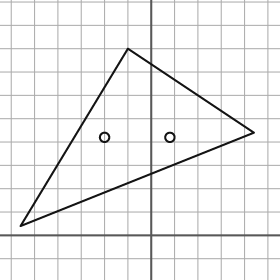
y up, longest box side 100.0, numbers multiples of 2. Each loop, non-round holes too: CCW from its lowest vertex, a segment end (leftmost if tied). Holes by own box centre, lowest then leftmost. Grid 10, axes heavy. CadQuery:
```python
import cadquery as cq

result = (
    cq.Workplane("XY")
    .moveTo(-56.0, 4.0)
    .lineTo(44.0, 44.0)
    .lineTo(-10.0, 80.0)
    .close()
    .moveTo(-20.0, 42.0)
    .circle(2.0)
    .moveTo(8.0, 42.0)
    .circle(2.0)
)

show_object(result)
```